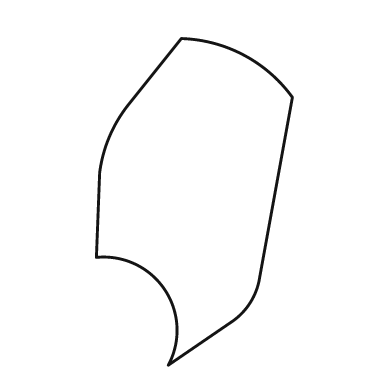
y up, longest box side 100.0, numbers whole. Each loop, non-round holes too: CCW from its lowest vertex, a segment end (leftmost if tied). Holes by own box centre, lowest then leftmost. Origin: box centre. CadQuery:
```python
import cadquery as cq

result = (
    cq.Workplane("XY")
    .moveTo(-8.0, -50.0)
    .lineTo(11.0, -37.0)
    .threePointArc((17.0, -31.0), (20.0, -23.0))
    .lineTo(30.0, 32.0)
    .threePointArc((15.0, 45.0), (-4.0, 50.0))
    .lineTo(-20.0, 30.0)
    .threePointArc((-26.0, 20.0), (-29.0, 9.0))
    .lineTo(-30.0, -17.0)
    .threePointArc((-9.0, -27.0), (-8.0, -50.0))
    .close()
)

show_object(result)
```